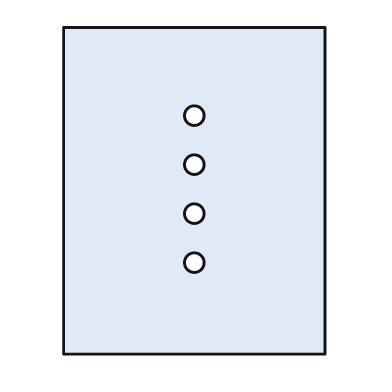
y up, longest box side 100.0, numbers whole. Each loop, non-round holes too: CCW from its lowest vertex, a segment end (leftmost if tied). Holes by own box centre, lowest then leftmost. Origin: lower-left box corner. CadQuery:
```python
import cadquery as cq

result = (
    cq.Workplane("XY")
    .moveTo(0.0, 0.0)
    .lineTo(80.0, 0.0)
    .lineTo(80.0, 100.0)
    .lineTo(0.0, 100.0)
    .close()
    .moveTo(40.0, 28.0)
    .circle(3.0)
    .moveTo(40.0, 43.0)
    .circle(3.0)
    .moveTo(40.0, 58.0)
    .circle(3.0)
    .moveTo(40.0, 73.0)
    .circle(3.0)
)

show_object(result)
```